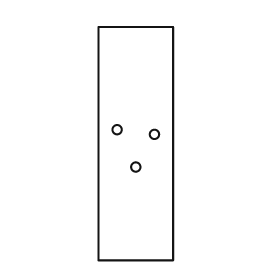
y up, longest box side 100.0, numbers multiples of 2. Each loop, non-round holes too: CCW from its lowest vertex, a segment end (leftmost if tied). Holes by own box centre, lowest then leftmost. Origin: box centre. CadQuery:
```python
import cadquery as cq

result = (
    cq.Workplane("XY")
    .moveTo(-16.0, -50.0)
    .lineTo(16.0, -50.0)
    .lineTo(16.0, 50.0)
    .lineTo(-16.0, 50.0)
    .close()
    .moveTo(0.0, -10.0)
    .circle(2.0)
    .moveTo(8.0, 4.0)
    .circle(2.0)
    .moveTo(-8.0, 6.0)
    .circle(2.0)
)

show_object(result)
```